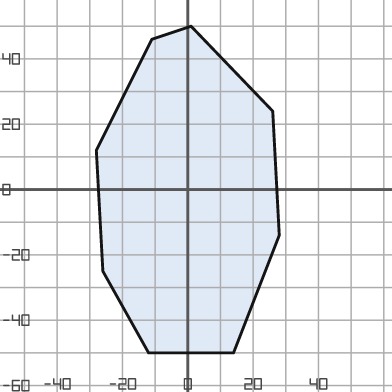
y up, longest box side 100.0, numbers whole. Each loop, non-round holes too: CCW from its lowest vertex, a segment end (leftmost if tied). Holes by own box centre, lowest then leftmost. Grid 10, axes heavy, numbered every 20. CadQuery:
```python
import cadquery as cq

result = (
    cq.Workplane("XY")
    .moveTo(-12.0, -50.0)
    .lineTo(14.0, -50.0)
    .lineTo(28.0, -14.0)
    .lineTo(26.0, 24.0)
    .lineTo(1.0, 50.0)
    .lineTo(-11.0, 46.0)
    .lineTo(-28.0, 12.0)
    .lineTo(-26.0, -25.0)
    .close()
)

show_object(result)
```